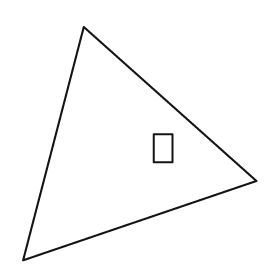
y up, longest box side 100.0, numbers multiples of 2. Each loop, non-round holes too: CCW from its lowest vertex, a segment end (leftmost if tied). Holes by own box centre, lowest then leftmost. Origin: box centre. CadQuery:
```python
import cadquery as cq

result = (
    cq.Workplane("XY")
    .moveTo(-50.0, -50.0)
    .lineTo(50.0, -16.0)
    .lineTo(-24.0, 50.0)
    .close()
    .moveTo(6.0, -8.0)
    .lineTo(14.0, -8.0)
    .lineTo(14.0, 4.0)
    .lineTo(6.0, 4.0)
    .close()
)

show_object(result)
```